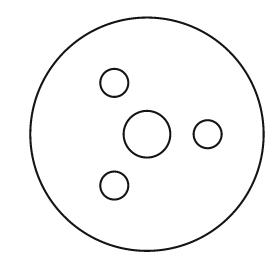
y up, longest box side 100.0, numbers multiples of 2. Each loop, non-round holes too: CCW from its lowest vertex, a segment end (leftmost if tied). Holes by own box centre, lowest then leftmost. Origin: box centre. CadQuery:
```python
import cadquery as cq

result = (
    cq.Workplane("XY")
    .moveTo(0.0, 0.0)
    .circle(50.0)
    .moveTo(-14.0, -22.0)
    .circle(6.0)
    .moveTo(0.0, 0.0)
    .circle(10.0)
    .moveTo(26.0, 0.0)
    .circle(6.0)
    .moveTo(-14.0, 22.0)
    .circle(6.0)
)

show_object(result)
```